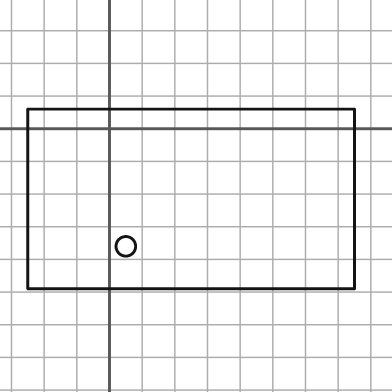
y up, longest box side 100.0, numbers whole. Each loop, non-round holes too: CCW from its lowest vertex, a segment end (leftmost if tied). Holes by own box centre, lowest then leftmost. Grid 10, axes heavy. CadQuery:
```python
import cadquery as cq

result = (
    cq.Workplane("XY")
    .moveTo(-25.0, -49.0)
    .lineTo(75.0, -49.0)
    .lineTo(75.0, 6.0)
    .lineTo(-25.0, 6.0)
    .close()
    .moveTo(5.0, -36.0)
    .circle(3.0)
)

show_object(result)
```